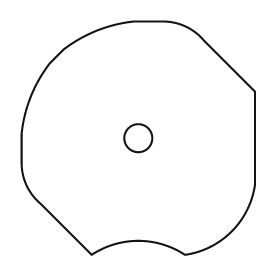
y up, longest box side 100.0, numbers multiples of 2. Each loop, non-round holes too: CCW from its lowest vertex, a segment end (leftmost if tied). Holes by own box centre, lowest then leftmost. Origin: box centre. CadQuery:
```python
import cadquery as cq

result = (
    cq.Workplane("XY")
    .moveTo(-20.0, -50.0)
    .threePointArc((0.0, -44.0), (20.0, -50.0))
    .threePointArc((40.0, -40.0), (50.0, -20.0))
    .lineTo(50.0, 20.0)
    .lineTo(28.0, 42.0)
    .threePointArc((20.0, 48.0), (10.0, 50.0))
    .lineTo(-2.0, 50.0)
    .threePointArc((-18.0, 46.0), (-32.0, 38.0))
    .lineTo(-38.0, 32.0)
    .threePointArc((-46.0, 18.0), (-50.0, 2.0))
    .lineTo(-50.0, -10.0)
    .threePointArc((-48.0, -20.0), (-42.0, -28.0))
    .close()
    .moveTo(0.0, 0.0)
    .circle(6.0)
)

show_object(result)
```